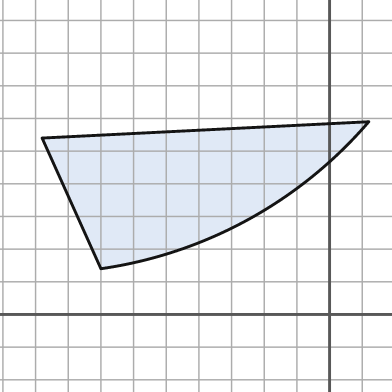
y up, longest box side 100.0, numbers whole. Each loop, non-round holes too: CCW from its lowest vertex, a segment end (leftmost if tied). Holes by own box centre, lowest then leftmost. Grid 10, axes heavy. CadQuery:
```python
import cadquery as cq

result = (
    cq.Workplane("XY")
    .moveTo(-70.0, 14.0)
    .threePointArc((-25.0, 29.0), (12.0, 59.0))
    .lineTo(-88.0, 54.0)
    .close()
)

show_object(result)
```